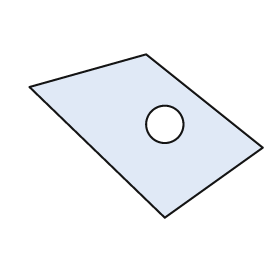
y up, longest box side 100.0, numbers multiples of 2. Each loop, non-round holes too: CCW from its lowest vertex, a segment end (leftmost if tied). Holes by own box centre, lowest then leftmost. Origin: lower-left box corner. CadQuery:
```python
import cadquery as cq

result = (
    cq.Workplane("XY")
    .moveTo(58.0, 0.0)
    .lineTo(100.0, 30.0)
    .lineTo(50.0, 70.0)
    .lineTo(0.0, 56.0)
    .close()
    .moveTo(58.0, 40.0)
    .circle(8.0)
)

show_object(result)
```